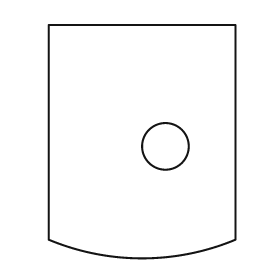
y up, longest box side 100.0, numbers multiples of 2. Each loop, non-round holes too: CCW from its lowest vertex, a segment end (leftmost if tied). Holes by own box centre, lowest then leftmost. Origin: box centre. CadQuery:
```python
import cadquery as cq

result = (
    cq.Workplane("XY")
    .moveTo(-40.0, -42.0)
    .threePointArc((0.0, -50.0), (40.0, -42.0))
    .lineTo(40.0, 50.0)
    .lineTo(-40.0, 50.0)
    .close()
    .moveTo(10.0, -2.0)
    .circle(10.0)
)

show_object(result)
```